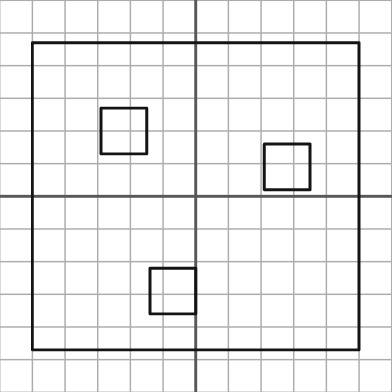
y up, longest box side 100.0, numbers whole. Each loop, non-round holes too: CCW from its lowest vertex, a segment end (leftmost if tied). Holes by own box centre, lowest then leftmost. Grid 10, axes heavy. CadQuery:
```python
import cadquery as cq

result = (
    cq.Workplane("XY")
    .moveTo(-50.0, -47.0)
    .lineTo(50.0, -47.0)
    .lineTo(50.0, 47.0)
    .lineTo(-50.0, 47.0)
    .close()
    .moveTo(-14.0, -36.0)
    .lineTo(0.0, -36.0)
    .lineTo(0.0, -22.0)
    .lineTo(-14.0, -22.0)
    .close()
    .moveTo(21.0, 2.0)
    .lineTo(35.0, 2.0)
    .lineTo(35.0, 16.0)
    .lineTo(21.0, 16.0)
    .close()
    .moveTo(-29.0, 13.0)
    .lineTo(-15.0, 13.0)
    .lineTo(-15.0, 27.0)
    .lineTo(-29.0, 27.0)
    .close()
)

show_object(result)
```